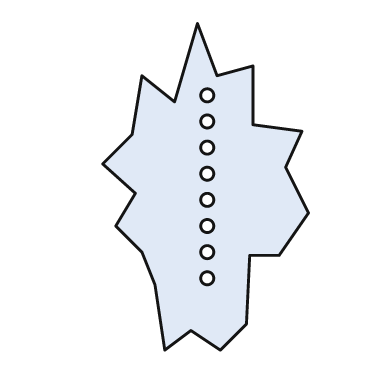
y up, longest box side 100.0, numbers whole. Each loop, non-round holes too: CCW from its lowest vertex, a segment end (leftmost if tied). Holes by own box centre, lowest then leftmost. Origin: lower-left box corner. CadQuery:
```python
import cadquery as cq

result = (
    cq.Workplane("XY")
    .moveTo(19.0, 0.0)
    .lineTo(27.0, 6.0)
    .lineTo(36.0, 0.0)
    .lineTo(44.0, 8.0)
    .lineTo(45.0, 29.0)
    .lineTo(54.0, 29.0)
    .lineTo(63.0, 42.0)
    .lineTo(56.0, 56.0)
    .lineTo(61.0, 67.0)
    .lineTo(46.0, 69.0)
    .lineTo(46.0, 87.0)
    .lineTo(35.0, 84.0)
    .lineTo(29.0, 100.0)
    .lineTo(22.0, 76.0)
    .lineTo(12.0, 84.0)
    .lineTo(9.0, 66.0)
    .lineTo(0.0, 57.0)
    .lineTo(10.0, 48.0)
    .lineTo(4.0, 38.0)
    .lineTo(12.0, 30.0)
    .lineTo(16.0, 20.0)
    .close()
    .moveTo(32.0, 22.0)
    .circle(2.0)
    .moveTo(32.0, 30.0)
    .circle(2.0)
    .moveTo(32.0, 38.0)
    .circle(2.0)
    .moveTo(32.0, 46.0)
    .circle(2.0)
    .moveTo(32.0, 54.0)
    .circle(2.0)
    .moveTo(32.0, 62.0)
    .circle(2.0)
    .moveTo(32.0, 70.0)
    .circle(2.0)
    .moveTo(32.0, 78.0)
    .circle(2.0)
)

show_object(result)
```